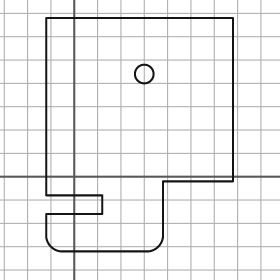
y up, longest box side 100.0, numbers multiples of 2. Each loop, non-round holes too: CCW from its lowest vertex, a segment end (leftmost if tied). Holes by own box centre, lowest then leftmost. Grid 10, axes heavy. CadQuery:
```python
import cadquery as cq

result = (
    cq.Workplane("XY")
    .moveTo(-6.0, -32.0)
    .lineTo(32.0, -32.0)
    .threePointArc((36.0, -30.0), (38.0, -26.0))
    .lineTo(38.0, -2.0)
    .lineTo(68.0, -2.0)
    .lineTo(68.0, 68.0)
    .lineTo(-12.0, 68.0)
    .lineTo(-12.0, -8.0)
    .lineTo(12.0, -8.0)
    .lineTo(12.0, -16.0)
    .lineTo(-12.0, -16.0)
    .lineTo(-12.0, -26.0)
    .threePointArc((-10.0, -30.0), (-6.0, -32.0))
    .close()
    .moveTo(30.0, 44.0)
    .circle(4.0)
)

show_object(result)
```